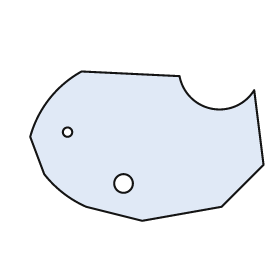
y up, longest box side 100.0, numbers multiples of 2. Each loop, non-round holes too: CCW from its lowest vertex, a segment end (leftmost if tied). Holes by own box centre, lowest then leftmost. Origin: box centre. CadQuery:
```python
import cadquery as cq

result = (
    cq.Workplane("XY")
    .moveTo(-2.0, -32.0)
    .lineTo(32.0, -26.0)
    .lineTo(50.0, -8.0)
    .lineTo(46.0, 24.0)
    .threePointArc((28.0, 16.0), (14.0, 30.0))
    .lineTo(-28.0, 32.0)
    .threePointArc((-42.0, 20.0), (-50.0, 4.0))
    .lineTo(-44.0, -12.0)
    .threePointArc((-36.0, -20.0), (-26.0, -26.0))
    .close()
    .moveTo(-10.0, -16.0)
    .circle(4.0)
    .moveTo(-34.0, 6.0)
    .circle(2.0)
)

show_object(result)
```